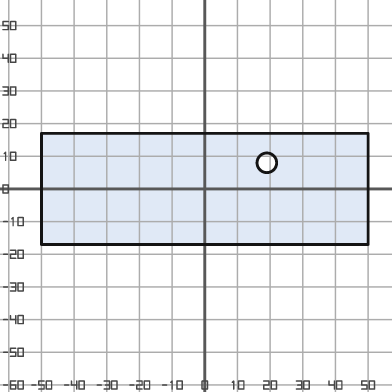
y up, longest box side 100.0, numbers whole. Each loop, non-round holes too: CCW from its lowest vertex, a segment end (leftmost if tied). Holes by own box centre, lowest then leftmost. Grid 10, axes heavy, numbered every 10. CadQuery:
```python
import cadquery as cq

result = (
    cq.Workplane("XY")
    .moveTo(-50.0, -17.0)
    .lineTo(50.0, -17.0)
    .lineTo(50.0, 17.0)
    .lineTo(-50.0, 17.0)
    .close()
    .moveTo(19.0, 8.0)
    .circle(3.0)
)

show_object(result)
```